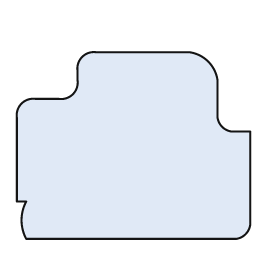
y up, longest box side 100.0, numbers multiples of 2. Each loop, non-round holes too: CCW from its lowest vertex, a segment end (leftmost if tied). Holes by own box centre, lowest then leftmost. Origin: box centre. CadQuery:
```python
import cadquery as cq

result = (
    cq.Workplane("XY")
    .moveTo(-46.0, -40.0)
    .lineTo(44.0, -40.0)
    .threePointArc((48.0, -38.0), (50.0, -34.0))
    .lineTo(50.0, 6.0)
    .lineTo(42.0, 6.0)
    .threePointArc((38.0, 8.0), (36.0, 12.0))
    .lineTo(36.0, 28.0)
    .threePointArc((32.0, 36.0), (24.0, 40.0))
    .lineTo(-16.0, 40.0)
    .threePointArc((-22.0, 38.0), (-24.0, 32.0))
    .lineTo(-24.0, 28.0)
    .threePointArc((-26.0, 22.0), (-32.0, 20.0))
    .lineTo(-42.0, 20.0)
    .threePointArc((-48.0, 18.0), (-50.0, 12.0))
    .lineTo(-50.0, -24.0)
    .lineTo(-46.0, -24.0)
    .threePointArc((-48.0, -32.0), (-46.0, -40.0))
    .close()
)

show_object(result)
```